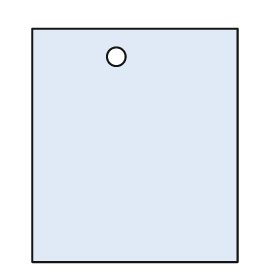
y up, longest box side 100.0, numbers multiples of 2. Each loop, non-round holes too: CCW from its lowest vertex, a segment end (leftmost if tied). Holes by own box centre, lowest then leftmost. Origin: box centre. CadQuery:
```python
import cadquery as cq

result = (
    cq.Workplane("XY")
    .moveTo(-44.0, -50.0)
    .lineTo(44.0, -50.0)
    .lineTo(44.0, 50.0)
    .lineTo(-44.0, 50.0)
    .close()
    .moveTo(-8.0, 38.0)
    .circle(4.0)
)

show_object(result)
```